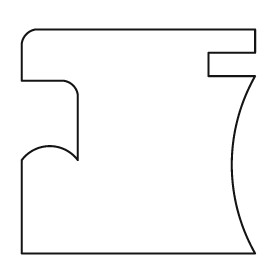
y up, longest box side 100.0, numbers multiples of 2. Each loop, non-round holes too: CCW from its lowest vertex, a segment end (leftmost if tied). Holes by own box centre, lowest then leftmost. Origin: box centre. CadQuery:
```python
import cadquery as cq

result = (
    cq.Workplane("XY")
    .moveTo(-50.0, -48.0)
    .lineTo(50.0, -48.0)
    .threePointArc((40.0, -10.0), (50.0, 28.0))
    .lineTo(30.0, 28.0)
    .lineTo(30.0, 38.0)
    .lineTo(50.0, 38.0)
    .lineTo(50.0, 48.0)
    .lineTo(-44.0, 48.0)
    .threePointArc((-48.0, 46.0), (-50.0, 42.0))
    .lineTo(-50.0, 26.0)
    .lineTo(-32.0, 26.0)
    .threePointArc((-28.0, 24.0), (-26.0, 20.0))
    .lineTo(-26.0, -8.0)
    .threePointArc((-38.0, -2.0), (-50.0, -8.0))
    .close()
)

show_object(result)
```